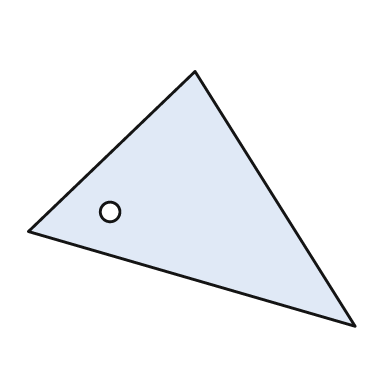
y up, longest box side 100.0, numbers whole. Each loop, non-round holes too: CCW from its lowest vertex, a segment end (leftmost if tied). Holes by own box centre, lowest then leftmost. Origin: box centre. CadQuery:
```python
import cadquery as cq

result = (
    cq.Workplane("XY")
    .moveTo(50.0, -39.0)
    .lineTo(1.0, 39.0)
    .lineTo(-50.0, -10.0)
    .close()
    .moveTo(-25.0, -4.0)
    .circle(3.0)
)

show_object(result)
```